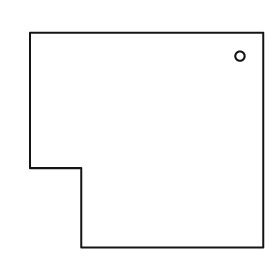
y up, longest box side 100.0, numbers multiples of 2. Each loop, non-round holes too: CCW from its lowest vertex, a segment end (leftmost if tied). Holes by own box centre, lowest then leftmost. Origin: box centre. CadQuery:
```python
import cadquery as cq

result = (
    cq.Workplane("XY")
    .moveTo(-28.0, -46.0)
    .lineTo(50.0, -46.0)
    .lineTo(50.0, 46.0)
    .lineTo(-50.0, 46.0)
    .lineTo(-50.0, -12.0)
    .lineTo(-28.0, -12.0)
    .close()
    .moveTo(40.0, 36.0)
    .circle(2.0)
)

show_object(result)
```